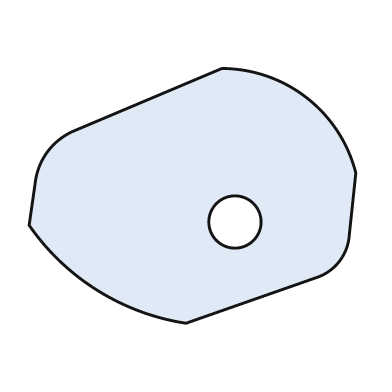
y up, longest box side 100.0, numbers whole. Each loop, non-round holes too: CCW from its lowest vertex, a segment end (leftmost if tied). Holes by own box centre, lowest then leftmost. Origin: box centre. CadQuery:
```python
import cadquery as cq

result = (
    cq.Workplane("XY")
    .moveTo(-2.0, -39.0)
    .lineTo(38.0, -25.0)
    .threePointArc((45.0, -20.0), (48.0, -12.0))
    .lineTo(50.0, 7.0)
    .threePointArc((35.0, 30.0), (9.0, 39.0))
    .lineTo(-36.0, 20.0)
    .threePointArc((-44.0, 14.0), (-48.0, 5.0))
    .lineTo(-50.0, -9.0)
    .threePointArc((-29.0, -29.0), (-2.0, -39.0))
    .close()
    .moveTo(13.0, -8.0)
    .circle(8.0)
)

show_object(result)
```